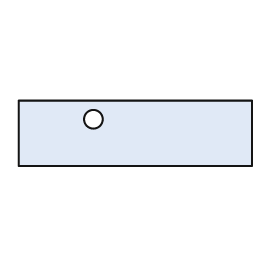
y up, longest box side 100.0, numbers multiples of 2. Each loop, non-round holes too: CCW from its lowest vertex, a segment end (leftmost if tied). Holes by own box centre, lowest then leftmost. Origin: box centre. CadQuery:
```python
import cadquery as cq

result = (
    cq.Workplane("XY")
    .moveTo(-50.0, -14.0)
    .lineTo(50.0, -14.0)
    .lineTo(50.0, 14.0)
    .lineTo(-50.0, 14.0)
    .close()
    .moveTo(-18.0, 6.0)
    .circle(4.0)
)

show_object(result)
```